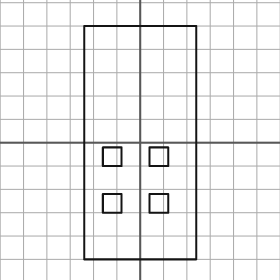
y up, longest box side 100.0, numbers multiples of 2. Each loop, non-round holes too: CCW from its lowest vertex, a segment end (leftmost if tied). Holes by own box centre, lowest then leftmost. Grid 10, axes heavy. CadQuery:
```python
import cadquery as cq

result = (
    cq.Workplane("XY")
    .moveTo(-24.0, -50.0)
    .lineTo(24.0, -50.0)
    .lineTo(24.0, 50.0)
    .lineTo(-24.0, 50.0)
    .close()
    .moveTo(-16.0, -30.0)
    .lineTo(-8.0, -30.0)
    .lineTo(-8.0, -22.0)
    .lineTo(-16.0, -22.0)
    .close()
    .moveTo(4.0, -30.0)
    .lineTo(12.0, -30.0)
    .lineTo(12.0, -22.0)
    .lineTo(4.0, -22.0)
    .close()
    .moveTo(-16.0, -10.0)
    .lineTo(-8.0, -10.0)
    .lineTo(-8.0, -2.0)
    .lineTo(-16.0, -2.0)
    .close()
    .moveTo(4.0, -10.0)
    .lineTo(12.0, -10.0)
    .lineTo(12.0, -2.0)
    .lineTo(4.0, -2.0)
    .close()
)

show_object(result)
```